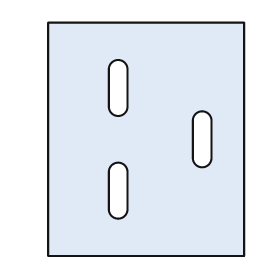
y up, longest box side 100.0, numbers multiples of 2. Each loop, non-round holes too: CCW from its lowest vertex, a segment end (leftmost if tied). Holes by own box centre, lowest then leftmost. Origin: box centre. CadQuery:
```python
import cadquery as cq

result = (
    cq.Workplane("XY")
    .moveTo(-42.0, -50.0)
    .lineTo(42.0, -50.0)
    .lineTo(42.0, 50.0)
    .lineTo(-42.0, 50.0)
    .close()
    .moveTo(-16.0, -30.0)
    .threePointArc((-12.0, -34.0), (-8.0, -30.0))
    .lineTo(-8.0, -14.0)
    .threePointArc((-12.0, -10.0), (-16.0, -14.0))
    .close()
    .moveTo(20.0, -8.0)
    .threePointArc((24.0, -12.0), (28.0, -8.0))
    .lineTo(28.0, 8.0)
    .threePointArc((24.0, 12.0), (20.0, 8.0))
    .close()
    .moveTo(-16.0, 14.0)
    .threePointArc((-12.0, 10.0), (-8.0, 14.0))
    .lineTo(-8.0, 30.0)
    .threePointArc((-12.0, 34.0), (-16.0, 30.0))
    .close()
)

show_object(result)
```